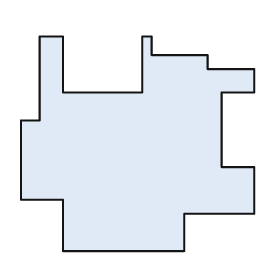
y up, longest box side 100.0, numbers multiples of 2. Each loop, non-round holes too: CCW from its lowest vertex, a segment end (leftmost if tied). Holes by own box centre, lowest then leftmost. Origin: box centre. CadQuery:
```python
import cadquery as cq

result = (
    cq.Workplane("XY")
    .moveTo(-32.0, -46.0)
    .lineTo(20.0, -46.0)
    .lineTo(20.0, -30.0)
    .lineTo(50.0, -30.0)
    .lineTo(50.0, -10.0)
    .lineTo(36.0, -10.0)
    .lineTo(36.0, 22.0)
    .lineTo(50.0, 22.0)
    .lineTo(50.0, 32.0)
    .lineTo(30.0, 32.0)
    .lineTo(30.0, 38.0)
    .lineTo(6.0, 38.0)
    .lineTo(6.0, 46.0)
    .lineTo(2.0, 46.0)
    .lineTo(2.0, 22.0)
    .lineTo(-32.0, 22.0)
    .lineTo(-32.0, 46.0)
    .lineTo(-42.0, 46.0)
    .lineTo(-42.0, 10.0)
    .lineTo(-50.0, 10.0)
    .lineTo(-50.0, -24.0)
    .lineTo(-32.0, -24.0)
    .close()
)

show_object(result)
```